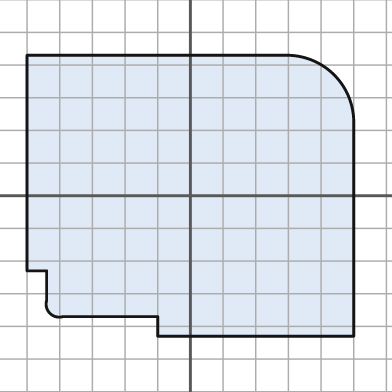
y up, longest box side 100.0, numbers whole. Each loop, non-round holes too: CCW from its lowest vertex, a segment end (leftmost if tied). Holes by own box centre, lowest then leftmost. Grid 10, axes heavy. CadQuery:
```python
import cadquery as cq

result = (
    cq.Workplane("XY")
    .moveTo(-10.0, -43.0)
    .lineTo(50.0, -43.0)
    .lineTo(50.0, 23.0)
    .threePointArc((44.0, 37.0), (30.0, 43.0))
    .lineTo(-50.0, 43.0)
    .lineTo(-50.0, -23.0)
    .lineTo(-44.0, -23.0)
    .lineTo(-44.0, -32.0)
    .threePointArc((-43.0, -36.0), (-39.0, -37.0))
    .lineTo(-10.0, -37.0)
    .close()
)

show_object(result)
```